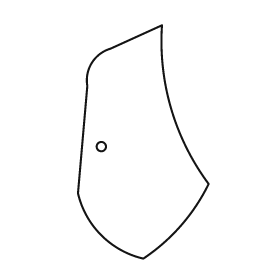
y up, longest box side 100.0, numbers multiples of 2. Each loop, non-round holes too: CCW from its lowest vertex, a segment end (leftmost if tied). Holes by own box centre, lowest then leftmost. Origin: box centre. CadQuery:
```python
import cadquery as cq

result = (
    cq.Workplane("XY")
    .moveTo(0.0, -50.0)
    .threePointArc((16.0, -36.0), (28.0, -18.0))
    .threePointArc((12.0, 14.0), (8.0, 50.0))
    .lineTo(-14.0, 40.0)
    .threePointArc((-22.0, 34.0), (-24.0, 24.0))
    .lineTo(-28.0, -22.0)
    .threePointArc((-18.0, -40.0), (0.0, -50.0))
    .close()
    .moveTo(-18.0, -2.0)
    .circle(2.0)
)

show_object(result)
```